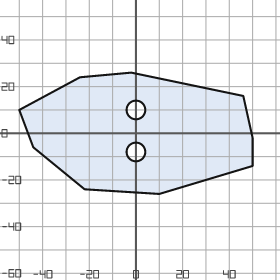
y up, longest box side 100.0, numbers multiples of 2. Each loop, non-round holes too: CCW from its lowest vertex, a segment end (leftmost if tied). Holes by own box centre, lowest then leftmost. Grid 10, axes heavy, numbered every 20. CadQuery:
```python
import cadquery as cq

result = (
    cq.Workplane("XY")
    .moveTo(10.0, -26.0)
    .lineTo(50.0, -14.0)
    .lineTo(50.0, -2.0)
    .lineTo(46.0, 16.0)
    .lineTo(-2.0, 26.0)
    .lineTo(-24.0, 24.0)
    .lineTo(-50.0, 10.0)
    .lineTo(-44.0, -6.0)
    .lineTo(-22.0, -24.0)
    .close()
    .moveTo(0.0, -8.0)
    .circle(4.0)
    .moveTo(0.0, 10.0)
    .circle(4.0)
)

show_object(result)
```